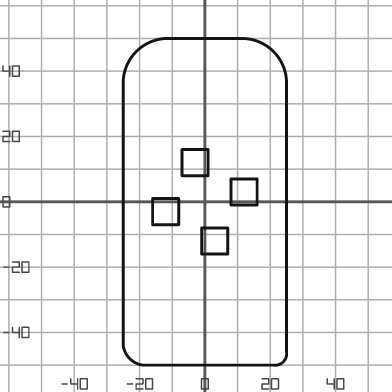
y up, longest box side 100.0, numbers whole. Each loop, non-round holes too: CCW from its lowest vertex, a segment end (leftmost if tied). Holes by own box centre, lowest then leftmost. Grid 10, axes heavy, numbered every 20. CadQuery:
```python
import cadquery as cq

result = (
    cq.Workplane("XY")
    .moveTo(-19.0, -50.0)
    .lineTo(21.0, -50.0)
    .threePointArc((24.0, -49.0), (25.0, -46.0))
    .lineTo(25.0, 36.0)
    .threePointArc((21.0, 46.0), (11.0, 50.0))
    .lineTo(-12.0, 50.0)
    .threePointArc((-21.0, 46.0), (-25.0, 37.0))
    .lineTo(-25.0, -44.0)
    .threePointArc((-23.0, -48.0), (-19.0, -50.0))
    .close()
    .moveTo(-1.0, -16.0)
    .lineTo(7.0, -16.0)
    .lineTo(7.0, -8.0)
    .lineTo(-1.0, -8.0)
    .close()
    .moveTo(-16.0, -7.0)
    .lineTo(-8.0, -7.0)
    .lineTo(-8.0, 1.0)
    .lineTo(-16.0, 1.0)
    .close()
    .moveTo(8.0, -1.0)
    .lineTo(16.0, -1.0)
    .lineTo(16.0, 7.0)
    .lineTo(8.0, 7.0)
    .close()
    .moveTo(-7.0, 8.0)
    .lineTo(1.0, 8.0)
    .lineTo(1.0, 16.0)
    .lineTo(-7.0, 16.0)
    .close()
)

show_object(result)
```